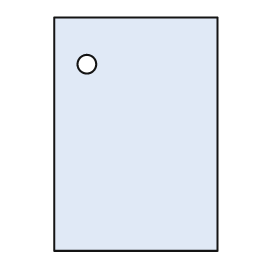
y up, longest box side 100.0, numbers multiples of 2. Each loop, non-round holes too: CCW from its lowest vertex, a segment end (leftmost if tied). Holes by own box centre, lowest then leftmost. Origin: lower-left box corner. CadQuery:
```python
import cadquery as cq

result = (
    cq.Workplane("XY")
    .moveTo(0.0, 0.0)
    .lineTo(70.0, 0.0)
    .lineTo(70.0, 100.0)
    .lineTo(0.0, 100.0)
    .close()
    .moveTo(14.0, 80.0)
    .circle(4.0)
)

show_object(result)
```